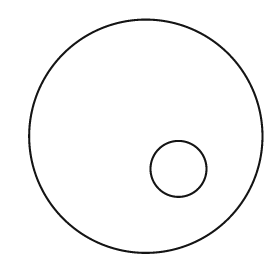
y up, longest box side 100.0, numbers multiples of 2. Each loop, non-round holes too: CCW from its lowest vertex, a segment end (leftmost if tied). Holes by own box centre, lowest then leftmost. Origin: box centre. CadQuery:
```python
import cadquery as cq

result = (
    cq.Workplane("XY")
    .moveTo(0.0, 0.0)
    .circle(50.0)
    .moveTo(14.0, -14.0)
    .circle(12.0)
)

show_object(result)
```